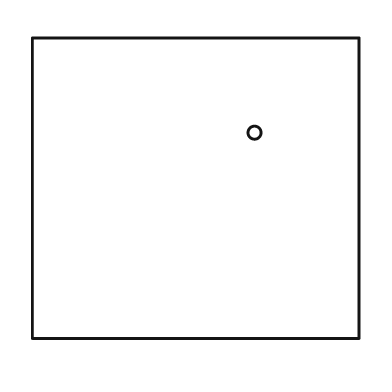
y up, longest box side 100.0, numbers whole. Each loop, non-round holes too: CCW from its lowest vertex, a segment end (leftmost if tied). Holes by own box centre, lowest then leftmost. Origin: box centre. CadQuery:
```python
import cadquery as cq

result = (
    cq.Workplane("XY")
    .moveTo(-50.0, -46.0)
    .lineTo(50.0, -46.0)
    .lineTo(50.0, 46.0)
    .lineTo(-50.0, 46.0)
    .close()
    .moveTo(18.0, 17.0)
    .circle(2.0)
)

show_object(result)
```